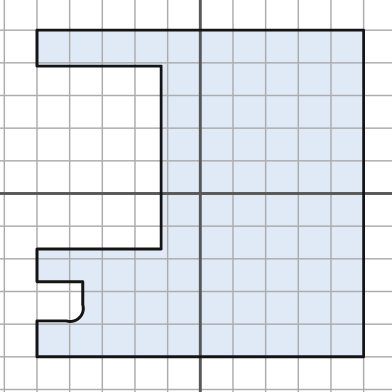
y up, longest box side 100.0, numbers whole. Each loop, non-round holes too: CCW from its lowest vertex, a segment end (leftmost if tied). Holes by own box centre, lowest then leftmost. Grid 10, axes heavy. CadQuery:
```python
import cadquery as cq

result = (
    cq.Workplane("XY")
    .moveTo(-50.0, -50.0)
    .lineTo(50.0, -50.0)
    .lineTo(50.0, 50.0)
    .lineTo(-50.0, 50.0)
    .lineTo(-50.0, 39.0)
    .lineTo(-12.0, 39.0)
    .lineTo(-12.0, -17.0)
    .lineTo(-50.0, -17.0)
    .lineTo(-50.0, -27.0)
    .lineTo(-36.0, -27.0)
    .lineTo(-36.0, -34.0)
    .threePointArc((-37.0, -38.0), (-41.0, -39.0))
    .lineTo(-50.0, -39.0)
    .close()
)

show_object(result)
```